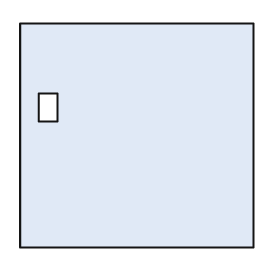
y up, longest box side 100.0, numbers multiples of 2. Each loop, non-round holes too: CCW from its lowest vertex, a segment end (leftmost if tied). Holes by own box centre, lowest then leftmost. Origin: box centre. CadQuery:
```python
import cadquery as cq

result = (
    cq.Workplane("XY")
    .moveTo(-50.0, -48.0)
    .lineTo(50.0, -48.0)
    .lineTo(50.0, 48.0)
    .lineTo(-50.0, 48.0)
    .close()
    .moveTo(-42.0, 6.0)
    .lineTo(-34.0, 6.0)
    .lineTo(-34.0, 18.0)
    .lineTo(-42.0, 18.0)
    .close()
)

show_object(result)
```